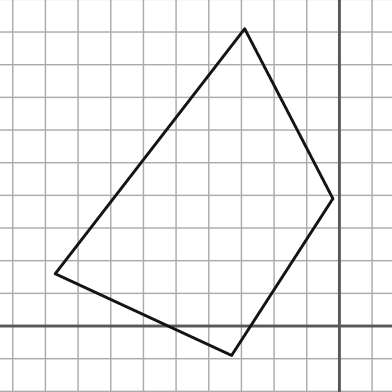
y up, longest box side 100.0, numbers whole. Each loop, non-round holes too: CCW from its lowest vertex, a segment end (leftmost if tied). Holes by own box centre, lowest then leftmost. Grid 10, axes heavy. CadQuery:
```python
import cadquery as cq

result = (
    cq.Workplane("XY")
    .moveTo(-33.0, -9.0)
    .lineTo(-2.0, 39.0)
    .lineTo(-29.0, 91.0)
    .lineTo(-87.0, 16.0)
    .close()
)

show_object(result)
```